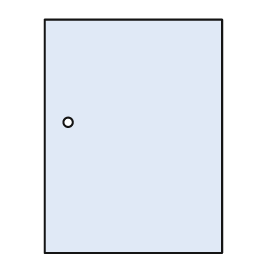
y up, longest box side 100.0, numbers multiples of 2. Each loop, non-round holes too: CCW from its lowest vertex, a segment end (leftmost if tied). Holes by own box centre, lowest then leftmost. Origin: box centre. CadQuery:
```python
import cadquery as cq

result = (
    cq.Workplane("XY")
    .moveTo(-38.0, -50.0)
    .lineTo(38.0, -50.0)
    .lineTo(38.0, 50.0)
    .lineTo(-38.0, 50.0)
    .close()
    .moveTo(-28.0, 6.0)
    .circle(2.0)
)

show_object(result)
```